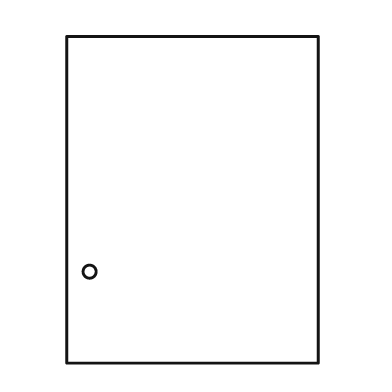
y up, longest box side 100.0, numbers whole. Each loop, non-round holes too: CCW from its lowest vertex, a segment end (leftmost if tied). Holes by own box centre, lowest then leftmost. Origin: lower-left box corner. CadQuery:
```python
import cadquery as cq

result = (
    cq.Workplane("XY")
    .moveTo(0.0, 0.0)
    .lineTo(77.0, 0.0)
    .lineTo(77.0, 100.0)
    .lineTo(0.0, 100.0)
    .close()
    .moveTo(7.0, 28.0)
    .circle(2.0)
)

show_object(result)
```